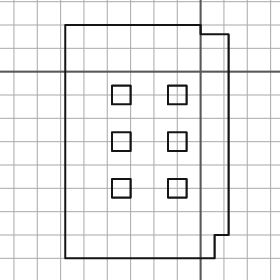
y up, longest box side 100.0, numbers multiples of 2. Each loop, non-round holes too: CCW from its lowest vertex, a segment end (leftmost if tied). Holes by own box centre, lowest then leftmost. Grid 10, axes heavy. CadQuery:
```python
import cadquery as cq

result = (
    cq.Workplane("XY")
    .moveTo(-58.0, -80.0)
    .lineTo(6.0, -80.0)
    .lineTo(6.0, -70.0)
    .lineTo(12.0, -70.0)
    .lineTo(12.0, 16.0)
    .lineTo(0.0, 16.0)
    .lineTo(0.0, 20.0)
    .lineTo(-58.0, 20.0)
    .close()
    .moveTo(-38.0, -54.0)
    .lineTo(-30.0, -54.0)
    .lineTo(-30.0, -46.0)
    .lineTo(-38.0, -46.0)
    .close()
    .moveTo(-14.0, -54.0)
    .lineTo(-6.0, -54.0)
    .lineTo(-6.0, -46.0)
    .lineTo(-14.0, -46.0)
    .close()
    .moveTo(-38.0, -34.0)
    .lineTo(-30.0, -34.0)
    .lineTo(-30.0, -26.0)
    .lineTo(-38.0, -26.0)
    .close()
    .moveTo(-14.0, -34.0)
    .lineTo(-6.0, -34.0)
    .lineTo(-6.0, -26.0)
    .lineTo(-14.0, -26.0)
    .close()
    .moveTo(-38.0, -14.0)
    .lineTo(-30.0, -14.0)
    .lineTo(-30.0, -6.0)
    .lineTo(-38.0, -6.0)
    .close()
    .moveTo(-14.0, -14.0)
    .lineTo(-6.0, -14.0)
    .lineTo(-6.0, -6.0)
    .lineTo(-14.0, -6.0)
    .close()
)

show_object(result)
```